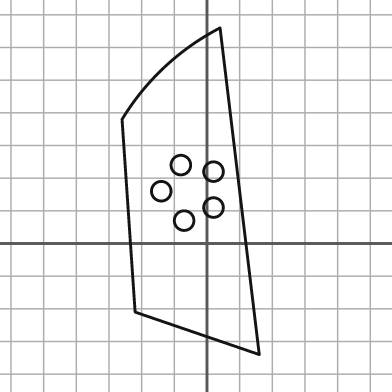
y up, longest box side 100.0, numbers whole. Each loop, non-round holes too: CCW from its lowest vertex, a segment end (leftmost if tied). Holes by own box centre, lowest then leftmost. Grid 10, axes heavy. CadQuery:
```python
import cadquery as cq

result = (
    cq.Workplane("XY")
    .moveTo(16.0, -34.0)
    .lineTo(4.0, 66.0)
    .threePointArc((-13.0, 54.0), (-26.0, 38.0))
    .lineTo(-22.0, -21.0)
    .close()
    .moveTo(-7.0, 7.0)
    .circle(3.0)
    .moveTo(2.0, 11.0)
    .circle(3.0)
    .moveTo(-14.0, 16.0)
    .circle(3.0)
    .moveTo(2.0, 22.0)
    .circle(3.0)
    .moveTo(-8.0, 24.0)
    .circle(3.0)
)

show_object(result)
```